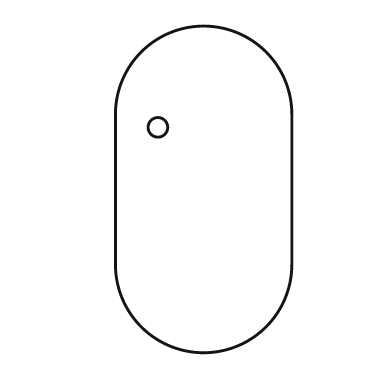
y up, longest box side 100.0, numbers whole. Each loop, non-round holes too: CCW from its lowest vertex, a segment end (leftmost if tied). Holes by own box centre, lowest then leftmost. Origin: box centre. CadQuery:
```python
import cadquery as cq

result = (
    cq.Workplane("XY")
    .moveTo(-27.0, -23.0)
    .threePointArc((0.0, -50.0), (27.0, -23.0))
    .lineTo(27.0, 23.0)
    .threePointArc((0.0, 50.0), (-27.0, 23.0))
    .close()
    .moveTo(-14.0, 19.0)
    .circle(3.0)
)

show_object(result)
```